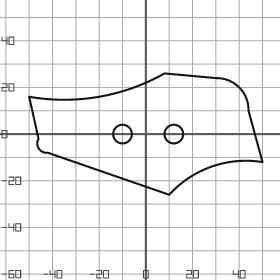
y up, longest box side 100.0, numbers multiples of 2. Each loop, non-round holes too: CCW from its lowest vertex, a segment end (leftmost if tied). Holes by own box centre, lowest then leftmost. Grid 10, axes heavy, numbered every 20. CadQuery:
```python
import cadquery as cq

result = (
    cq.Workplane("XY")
    .moveTo(10.0, -26.0)
    .threePointArc((28.0, -14.0), (50.0, -12.0))
    .lineTo(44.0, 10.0)
    .threePointArc((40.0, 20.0), (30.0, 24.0))
    .lineTo(8.0, 26.0)
    .threePointArc((-20.0, 16.0), (-50.0, 16.0))
    .lineTo(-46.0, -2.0)
    .threePointArc((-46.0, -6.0), (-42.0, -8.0))
    .close()
    .moveTo(-10.0, 0.0)
    .circle(4.0)
    .moveTo(12.0, 0.0)
    .circle(4.0)
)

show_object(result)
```